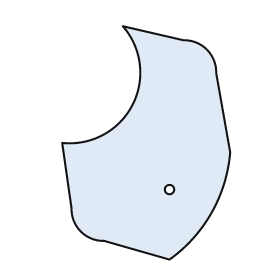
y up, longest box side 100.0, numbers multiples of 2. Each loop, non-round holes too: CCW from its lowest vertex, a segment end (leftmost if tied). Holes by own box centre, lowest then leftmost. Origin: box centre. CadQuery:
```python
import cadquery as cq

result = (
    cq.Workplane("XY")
    .moveTo(10.0, -50.0)
    .threePointArc((28.0, -30.0), (36.0, -4.0))
    .lineTo(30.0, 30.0)
    .threePointArc((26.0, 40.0), (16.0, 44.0))
    .lineTo(-10.0, 50.0)
    .threePointArc((-6.0, 16.0), (-36.0, 0.0))
    .lineTo(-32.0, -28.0)
    .threePointArc((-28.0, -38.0), (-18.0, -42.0))
    .close()
    .moveTo(10.0, -20.0)
    .circle(2.0)
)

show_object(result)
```